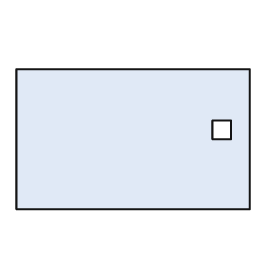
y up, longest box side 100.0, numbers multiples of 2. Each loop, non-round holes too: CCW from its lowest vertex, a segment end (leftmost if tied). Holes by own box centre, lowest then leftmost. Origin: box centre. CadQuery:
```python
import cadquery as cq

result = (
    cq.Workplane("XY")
    .moveTo(-50.0, -30.0)
    .lineTo(50.0, -30.0)
    .lineTo(50.0, 30.0)
    .lineTo(-50.0, 30.0)
    .close()
    .moveTo(34.0, 0.0)
    .lineTo(42.0, 0.0)
    .lineTo(42.0, 8.0)
    .lineTo(34.0, 8.0)
    .close()
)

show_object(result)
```